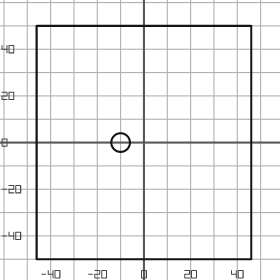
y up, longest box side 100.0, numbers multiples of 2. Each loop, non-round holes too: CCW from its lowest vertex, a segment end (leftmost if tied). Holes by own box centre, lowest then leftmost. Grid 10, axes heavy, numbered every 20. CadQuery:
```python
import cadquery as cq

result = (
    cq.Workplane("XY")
    .moveTo(-46.0, -50.0)
    .lineTo(46.0, -50.0)
    .lineTo(46.0, 50.0)
    .lineTo(-46.0, 50.0)
    .close()
    .moveTo(-10.0, 0.0)
    .circle(4.0)
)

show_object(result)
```